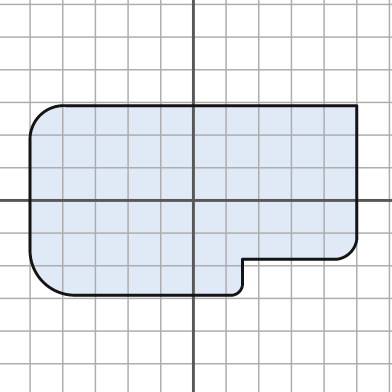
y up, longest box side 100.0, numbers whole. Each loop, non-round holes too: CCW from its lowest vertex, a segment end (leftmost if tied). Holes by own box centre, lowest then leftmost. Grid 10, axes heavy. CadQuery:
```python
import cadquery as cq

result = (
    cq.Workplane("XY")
    .moveTo(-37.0, -29.0)
    .lineTo(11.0, -29.0)
    .threePointArc((14.0, -28.0), (15.0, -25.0))
    .lineTo(15.0, -18.0)
    .lineTo(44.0, -18.0)
    .threePointArc((48.0, -16.0), (50.0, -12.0))
    .lineTo(50.0, 29.0)
    .lineTo(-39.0, 29.0)
    .threePointArc((-47.0, 26.0), (-50.0, 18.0))
    .lineTo(-50.0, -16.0)
    .threePointArc((-46.0, -25.0), (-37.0, -29.0))
    .close()
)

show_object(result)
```